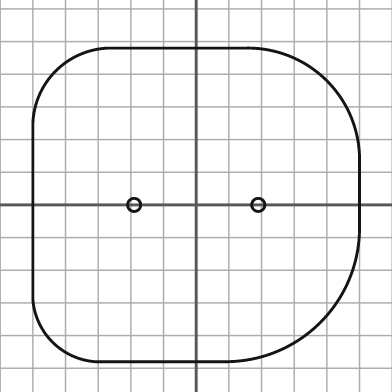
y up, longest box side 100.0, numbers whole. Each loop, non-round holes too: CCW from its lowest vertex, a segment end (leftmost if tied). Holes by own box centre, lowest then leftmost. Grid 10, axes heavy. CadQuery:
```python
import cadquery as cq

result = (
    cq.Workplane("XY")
    .moveTo(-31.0, -48.0)
    .lineTo(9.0, -48.0)
    .threePointArc((38.0, -36.0), (50.0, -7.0))
    .lineTo(50.0, 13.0)
    .threePointArc((40.0, 38.0), (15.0, 48.0))
    .lineTo(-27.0, 48.0)
    .threePointArc((-43.0, 41.0), (-50.0, 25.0))
    .lineTo(-50.0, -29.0)
    .threePointArc((-44.0, -42.0), (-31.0, -48.0))
    .close()
    .moveTo(-19.0, 0.0)
    .circle(2.0)
    .moveTo(19.0, 0.0)
    .circle(2.0)
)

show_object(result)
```